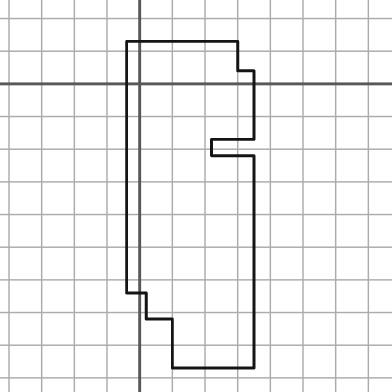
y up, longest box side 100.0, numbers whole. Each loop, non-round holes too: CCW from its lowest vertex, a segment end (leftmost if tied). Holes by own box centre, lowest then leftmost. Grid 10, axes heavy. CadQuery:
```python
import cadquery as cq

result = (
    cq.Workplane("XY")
    .moveTo(10.0, -87.0)
    .lineTo(35.0, -87.0)
    .lineTo(35.0, -22.0)
    .lineTo(22.0, -22.0)
    .lineTo(22.0, -17.0)
    .lineTo(35.0, -17.0)
    .lineTo(35.0, 4.0)
    .lineTo(30.0, 4.0)
    .lineTo(30.0, 13.0)
    .lineTo(-4.0, 13.0)
    .lineTo(-4.0, -64.0)
    .lineTo(2.0, -64.0)
    .lineTo(2.0, -72.0)
    .lineTo(10.0, -72.0)
    .close()
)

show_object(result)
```